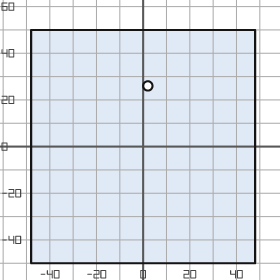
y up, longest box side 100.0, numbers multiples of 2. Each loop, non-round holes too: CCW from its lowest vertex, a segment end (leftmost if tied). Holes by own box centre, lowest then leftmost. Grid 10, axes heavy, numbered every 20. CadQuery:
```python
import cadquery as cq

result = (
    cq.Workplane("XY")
    .moveTo(-48.0, -50.0)
    .lineTo(48.0, -50.0)
    .lineTo(48.0, 50.0)
    .lineTo(-48.0, 50.0)
    .close()
    .moveTo(2.0, 26.0)
    .circle(2.0)
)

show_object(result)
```